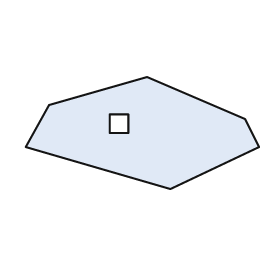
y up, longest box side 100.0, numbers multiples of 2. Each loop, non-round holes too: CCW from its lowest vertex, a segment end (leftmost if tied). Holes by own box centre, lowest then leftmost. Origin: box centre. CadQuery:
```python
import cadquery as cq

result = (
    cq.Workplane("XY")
    .moveTo(12.0, -24.0)
    .lineTo(50.0, -6.0)
    .lineTo(44.0, 6.0)
    .lineTo(2.0, 24.0)
    .lineTo(-40.0, 12.0)
    .lineTo(-50.0, -6.0)
    .close()
    .moveTo(-14.0, 0.0)
    .lineTo(-6.0, 0.0)
    .lineTo(-6.0, 8.0)
    .lineTo(-14.0, 8.0)
    .close()
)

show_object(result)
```